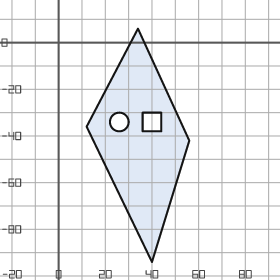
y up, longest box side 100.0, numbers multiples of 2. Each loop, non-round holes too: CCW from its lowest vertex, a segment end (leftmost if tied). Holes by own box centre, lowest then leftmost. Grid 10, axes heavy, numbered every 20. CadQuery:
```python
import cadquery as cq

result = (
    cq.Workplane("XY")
    .moveTo(40.0, -94.0)
    .lineTo(56.0, -42.0)
    .lineTo(34.0, 6.0)
    .lineTo(12.0, -36.0)
    .close()
    .moveTo(26.0, -34.0)
    .circle(4.0)
    .moveTo(36.0, -38.0)
    .lineTo(44.0, -38.0)
    .lineTo(44.0, -30.0)
    .lineTo(36.0, -30.0)
    .close()
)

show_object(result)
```